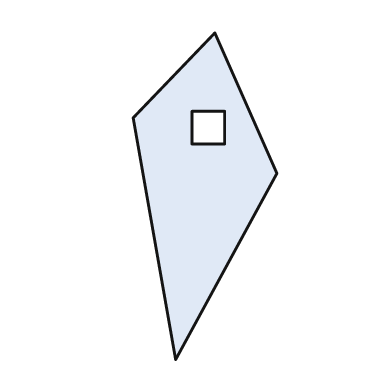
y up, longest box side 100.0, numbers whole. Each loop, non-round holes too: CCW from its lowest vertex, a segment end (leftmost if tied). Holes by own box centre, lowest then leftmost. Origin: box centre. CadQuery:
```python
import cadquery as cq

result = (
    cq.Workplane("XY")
    .moveTo(-9.0, -50.0)
    .lineTo(22.0, 7.0)
    .lineTo(3.0, 50.0)
    .lineTo(-22.0, 24.0)
    .close()
    .moveTo(-4.0, 16.0)
    .lineTo(6.0, 16.0)
    .lineTo(6.0, 26.0)
    .lineTo(-4.0, 26.0)
    .close()
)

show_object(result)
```